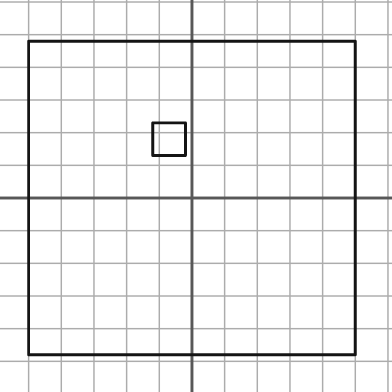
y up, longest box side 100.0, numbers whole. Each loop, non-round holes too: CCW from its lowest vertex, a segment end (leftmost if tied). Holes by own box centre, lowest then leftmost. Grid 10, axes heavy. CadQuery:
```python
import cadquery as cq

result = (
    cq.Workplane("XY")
    .moveTo(-50.0, -48.0)
    .lineTo(50.0, -48.0)
    .lineTo(50.0, 48.0)
    .lineTo(-50.0, 48.0)
    .close()
    .moveTo(-12.0, 13.0)
    .lineTo(-2.0, 13.0)
    .lineTo(-2.0, 23.0)
    .lineTo(-12.0, 23.0)
    .close()
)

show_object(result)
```